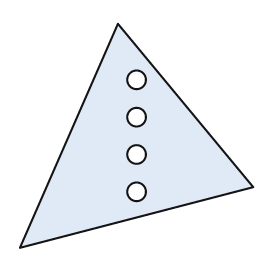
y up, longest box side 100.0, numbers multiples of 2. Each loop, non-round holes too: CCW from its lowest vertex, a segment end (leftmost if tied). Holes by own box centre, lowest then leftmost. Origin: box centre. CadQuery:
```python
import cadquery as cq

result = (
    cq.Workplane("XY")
    .moveTo(-50.0, -48.0)
    .lineTo(50.0, -22.0)
    .lineTo(-8.0, 48.0)
    .close()
    .moveTo(0.0, -24.0)
    .circle(4.0)
    .moveTo(0.0, -8.0)
    .circle(4.0)
    .moveTo(0.0, 8.0)
    .circle(4.0)
    .moveTo(0.0, 24.0)
    .circle(4.0)
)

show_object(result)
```